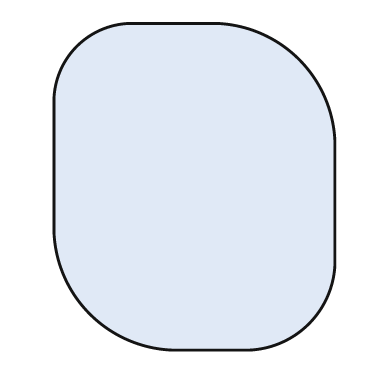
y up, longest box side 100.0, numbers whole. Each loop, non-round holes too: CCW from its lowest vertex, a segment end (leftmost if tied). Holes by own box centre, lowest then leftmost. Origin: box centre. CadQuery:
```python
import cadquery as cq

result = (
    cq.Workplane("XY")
    .moveTo(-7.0, -50.0)
    .lineTo(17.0, -50.0)
    .threePointArc((35.0, -42.0), (43.0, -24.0))
    .lineTo(43.0, 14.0)
    .threePointArc((32.0, 39.0), (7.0, 50.0))
    .lineTo(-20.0, 50.0)
    .threePointArc((-36.0, 43.0), (-43.0, 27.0))
    .lineTo(-43.0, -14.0)
    .threePointArc((-32.0, -39.0), (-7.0, -50.0))
    .close()
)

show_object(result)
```